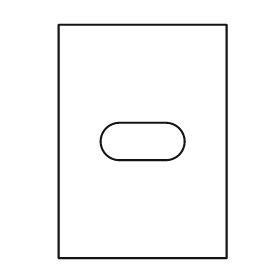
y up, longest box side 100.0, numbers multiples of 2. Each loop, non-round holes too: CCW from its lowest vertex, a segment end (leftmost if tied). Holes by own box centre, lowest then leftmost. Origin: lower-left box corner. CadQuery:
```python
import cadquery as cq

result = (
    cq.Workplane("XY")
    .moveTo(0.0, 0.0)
    .lineTo(72.0, 0.0)
    .lineTo(72.0, 100.0)
    .lineTo(0.0, 100.0)
    .close()
    .moveTo(26.0, 42.0)
    .lineTo(46.0, 42.0)
    .threePointArc((54.0, 50.0), (46.0, 58.0))
    .lineTo(26.0, 58.0)
    .threePointArc((18.0, 50.0), (26.0, 42.0))
    .close()
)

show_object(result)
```